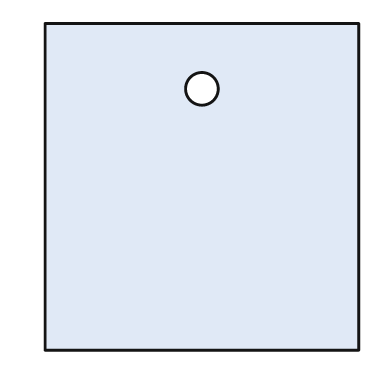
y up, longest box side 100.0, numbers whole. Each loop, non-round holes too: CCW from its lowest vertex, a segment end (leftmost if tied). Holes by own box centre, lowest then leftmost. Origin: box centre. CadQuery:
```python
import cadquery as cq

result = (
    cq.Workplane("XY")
    .moveTo(-48.0, -50.0)
    .lineTo(48.0, -50.0)
    .lineTo(48.0, 50.0)
    .lineTo(-48.0, 50.0)
    .close()
    .moveTo(0.0, 30.0)
    .circle(5.0)
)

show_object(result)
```